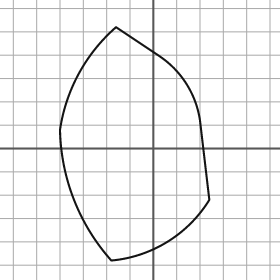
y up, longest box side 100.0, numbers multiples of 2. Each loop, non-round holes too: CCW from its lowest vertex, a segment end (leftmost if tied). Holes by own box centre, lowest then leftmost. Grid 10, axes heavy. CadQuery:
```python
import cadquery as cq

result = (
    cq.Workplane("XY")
    .moveTo(-18.0, -48.0)
    .threePointArc((6.0, -40.0), (24.0, -22.0))
    .lineTo(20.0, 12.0)
    .threePointArc((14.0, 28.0), (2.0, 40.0))
    .lineTo(-16.0, 52.0)
    .threePointArc((-32.0, 32.0), (-40.0, 8.0))
    .threePointArc((-34.0, -22.0), (-18.0, -48.0))
    .close()
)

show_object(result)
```